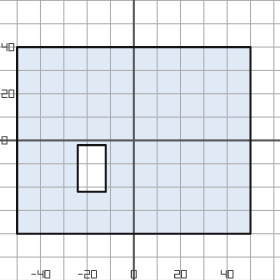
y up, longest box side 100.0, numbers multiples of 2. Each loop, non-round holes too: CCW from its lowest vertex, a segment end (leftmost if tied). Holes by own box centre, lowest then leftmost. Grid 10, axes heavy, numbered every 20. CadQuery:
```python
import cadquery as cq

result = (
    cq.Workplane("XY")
    .moveTo(-50.0, -40.0)
    .lineTo(50.0, -40.0)
    .lineTo(50.0, 40.0)
    .lineTo(-50.0, 40.0)
    .close()
    .moveTo(-24.0, -22.0)
    .lineTo(-12.0, -22.0)
    .lineTo(-12.0, -2.0)
    .lineTo(-24.0, -2.0)
    .close()
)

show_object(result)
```